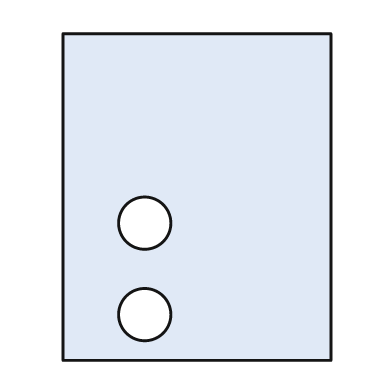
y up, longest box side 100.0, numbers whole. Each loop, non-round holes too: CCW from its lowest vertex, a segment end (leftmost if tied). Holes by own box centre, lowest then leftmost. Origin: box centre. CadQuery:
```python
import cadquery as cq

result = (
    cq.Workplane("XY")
    .moveTo(-41.0, -50.0)
    .lineTo(41.0, -50.0)
    .lineTo(41.0, 50.0)
    .lineTo(-41.0, 50.0)
    .close()
    .moveTo(-16.0, -36.0)
    .circle(8.0)
    .moveTo(-16.0, -8.0)
    .circle(8.0)
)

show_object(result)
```